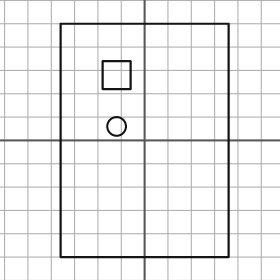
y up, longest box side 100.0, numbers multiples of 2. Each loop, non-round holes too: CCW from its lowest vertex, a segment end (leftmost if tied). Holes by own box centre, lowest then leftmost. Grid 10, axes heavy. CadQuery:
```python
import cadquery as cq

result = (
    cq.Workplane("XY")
    .moveTo(-36.0, -50.0)
    .lineTo(36.0, -50.0)
    .lineTo(36.0, 50.0)
    .lineTo(-36.0, 50.0)
    .close()
    .moveTo(-12.0, 6.0)
    .circle(4.0)
    .moveTo(-18.0, 22.0)
    .lineTo(-6.0, 22.0)
    .lineTo(-6.0, 34.0)
    .lineTo(-18.0, 34.0)
    .close()
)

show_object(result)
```